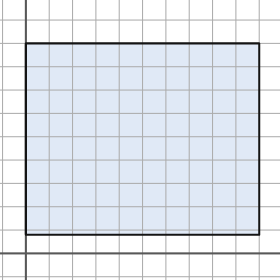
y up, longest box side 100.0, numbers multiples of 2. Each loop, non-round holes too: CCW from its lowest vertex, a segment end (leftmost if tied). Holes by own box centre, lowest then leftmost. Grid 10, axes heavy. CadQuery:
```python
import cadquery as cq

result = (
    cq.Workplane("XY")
    .moveTo(0.0, 8.0)
    .lineTo(100.0, 8.0)
    .lineTo(100.0, 90.0)
    .lineTo(0.0, 90.0)
    .close()
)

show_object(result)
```